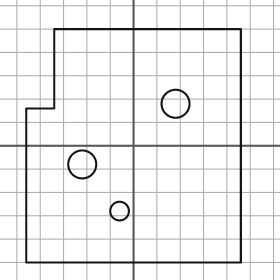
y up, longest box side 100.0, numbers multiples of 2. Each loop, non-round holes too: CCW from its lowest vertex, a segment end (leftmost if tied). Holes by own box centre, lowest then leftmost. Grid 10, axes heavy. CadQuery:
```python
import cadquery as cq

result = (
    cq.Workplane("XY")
    .moveTo(-46.0, -50.0)
    .lineTo(46.0, -50.0)
    .lineTo(46.0, 50.0)
    .lineTo(-34.0, 50.0)
    .lineTo(-34.0, 16.0)
    .lineTo(-46.0, 16.0)
    .close()
    .moveTo(-6.0, -28.0)
    .circle(4.0)
    .moveTo(-22.0, -8.0)
    .circle(6.0)
    .moveTo(18.0, 18.0)
    .circle(6.0)
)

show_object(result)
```